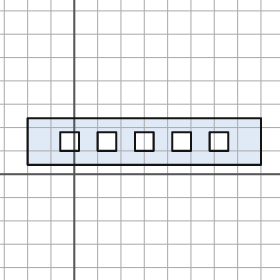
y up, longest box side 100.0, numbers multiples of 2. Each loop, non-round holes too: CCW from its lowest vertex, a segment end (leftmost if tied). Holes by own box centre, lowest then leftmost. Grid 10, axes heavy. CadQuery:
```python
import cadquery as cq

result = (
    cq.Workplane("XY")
    .moveTo(-20.0, 4.0)
    .lineTo(80.0, 4.0)
    .lineTo(80.0, 24.0)
    .lineTo(-20.0, 24.0)
    .close()
    .moveTo(-6.0, 10.0)
    .lineTo(2.0, 10.0)
    .lineTo(2.0, 18.0)
    .lineTo(-6.0, 18.0)
    .close()
    .moveTo(10.0, 10.0)
    .lineTo(18.0, 10.0)
    .lineTo(18.0, 18.0)
    .lineTo(10.0, 18.0)
    .close()
    .moveTo(26.0, 10.0)
    .lineTo(34.0, 10.0)
    .lineTo(34.0, 18.0)
    .lineTo(26.0, 18.0)
    .close()
    .moveTo(42.0, 10.0)
    .lineTo(50.0, 10.0)
    .lineTo(50.0, 18.0)
    .lineTo(42.0, 18.0)
    .close()
    .moveTo(58.0, 10.0)
    .lineTo(66.0, 10.0)
    .lineTo(66.0, 18.0)
    .lineTo(58.0, 18.0)
    .close()
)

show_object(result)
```